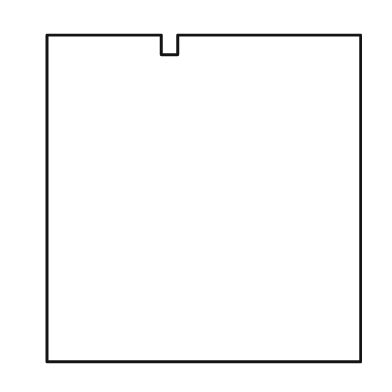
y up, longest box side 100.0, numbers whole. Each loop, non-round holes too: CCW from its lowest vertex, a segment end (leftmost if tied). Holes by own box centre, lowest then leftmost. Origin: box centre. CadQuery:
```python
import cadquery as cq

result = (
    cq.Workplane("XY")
    .moveTo(-48.0, -50.0)
    .lineTo(48.0, -50.0)
    .lineTo(48.0, 50.0)
    .lineTo(-8.0, 50.0)
    .lineTo(-8.0, 44.0)
    .lineTo(-13.0, 44.0)
    .lineTo(-13.0, 50.0)
    .lineTo(-48.0, 50.0)
    .close()
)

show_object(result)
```